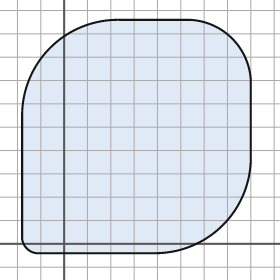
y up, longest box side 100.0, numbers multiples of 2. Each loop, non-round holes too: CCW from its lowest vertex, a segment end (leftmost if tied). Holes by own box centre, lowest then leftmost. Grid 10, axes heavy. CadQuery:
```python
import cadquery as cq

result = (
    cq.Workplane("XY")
    .moveTo(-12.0, -4.0)
    .lineTo(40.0, -4.0)
    .threePointArc((68.0, 8.0), (80.0, 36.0))
    .lineTo(80.0, 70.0)
    .threePointArc((72.0, 88.0), (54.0, 96.0))
    .lineTo(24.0, 96.0)
    .threePointArc((-6.0, 84.0), (-18.0, 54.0))
    .lineTo(-18.0, 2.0)
    .threePointArc((-16.0, -2.0), (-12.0, -4.0))
    .close()
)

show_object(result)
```